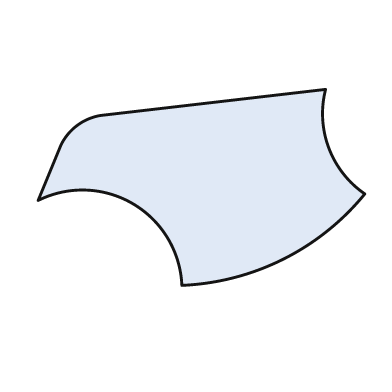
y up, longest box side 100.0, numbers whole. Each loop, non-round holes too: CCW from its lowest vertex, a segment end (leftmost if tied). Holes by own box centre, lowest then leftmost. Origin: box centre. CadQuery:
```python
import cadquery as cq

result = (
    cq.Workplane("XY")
    .moveTo(-6.0, -30.0)
    .threePointArc((25.0, -22.0), (50.0, -2.0))
    .threePointArc((39.0, 12.0), (38.0, 30.0))
    .lineTo(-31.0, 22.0)
    .threePointArc((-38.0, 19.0), (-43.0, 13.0))
    .lineTo(-50.0, -4.0)
    .threePointArc((-21.0, -5.0), (-6.0, -30.0))
    .close()
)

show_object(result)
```